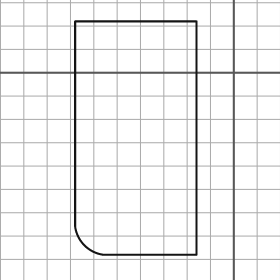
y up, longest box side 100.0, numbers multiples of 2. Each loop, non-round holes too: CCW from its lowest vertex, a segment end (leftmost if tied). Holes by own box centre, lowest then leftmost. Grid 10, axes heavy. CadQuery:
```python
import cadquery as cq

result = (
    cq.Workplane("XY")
    .moveTo(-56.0, -78.0)
    .lineTo(-16.0, -78.0)
    .lineTo(-16.0, 22.0)
    .lineTo(-68.0, 22.0)
    .lineTo(-68.0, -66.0)
    .threePointArc((-64.0, -74.0), (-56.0, -78.0))
    .close()
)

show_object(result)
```